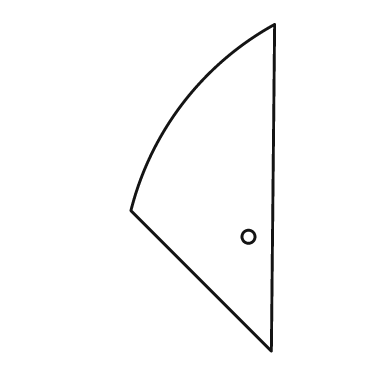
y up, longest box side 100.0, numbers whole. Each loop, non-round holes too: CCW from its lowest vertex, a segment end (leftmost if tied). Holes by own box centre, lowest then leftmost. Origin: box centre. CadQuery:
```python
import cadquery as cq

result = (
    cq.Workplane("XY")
    .moveTo(21.0, -50.0)
    .lineTo(22.0, 50.0)
    .threePointArc((-6.0, 26.0), (-22.0, -7.0))
    .close()
    .moveTo(14.0, -15.0)
    .circle(2.0)
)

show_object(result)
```